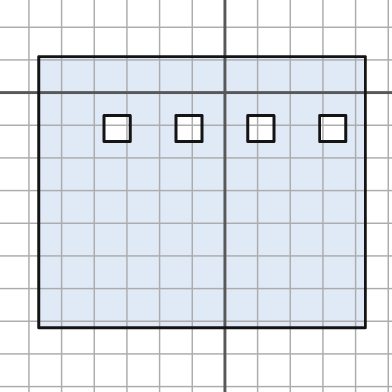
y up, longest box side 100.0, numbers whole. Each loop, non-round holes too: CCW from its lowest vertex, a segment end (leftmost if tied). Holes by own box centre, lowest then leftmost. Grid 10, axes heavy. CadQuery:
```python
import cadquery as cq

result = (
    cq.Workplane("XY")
    .moveTo(-57.0, -72.0)
    .lineTo(43.0, -72.0)
    .lineTo(43.0, 11.0)
    .lineTo(-57.0, 11.0)
    .close()
    .moveTo(-37.0, -15.0)
    .lineTo(-29.0, -15.0)
    .lineTo(-29.0, -7.0)
    .lineTo(-37.0, -7.0)
    .close()
    .moveTo(-15.0, -15.0)
    .lineTo(-7.0, -15.0)
    .lineTo(-7.0, -7.0)
    .lineTo(-15.0, -7.0)
    .close()
    .moveTo(7.0, -15.0)
    .lineTo(15.0, -15.0)
    .lineTo(15.0, -7.0)
    .lineTo(7.0, -7.0)
    .close()
    .moveTo(29.0, -15.0)
    .lineTo(37.0, -15.0)
    .lineTo(37.0, -7.0)
    .lineTo(29.0, -7.0)
    .close()
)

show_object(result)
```